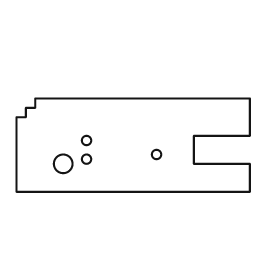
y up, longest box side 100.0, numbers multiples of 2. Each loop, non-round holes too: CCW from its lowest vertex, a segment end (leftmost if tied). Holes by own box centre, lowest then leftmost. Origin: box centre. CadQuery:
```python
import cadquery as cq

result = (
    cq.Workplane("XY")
    .moveTo(-50.0, -20.0)
    .lineTo(50.0, -20.0)
    .lineTo(50.0, -8.0)
    .lineTo(26.0, -8.0)
    .lineTo(26.0, 4.0)
    .lineTo(50.0, 4.0)
    .lineTo(50.0, 20.0)
    .lineTo(-42.0, 20.0)
    .lineTo(-42.0, 16.0)
    .lineTo(-46.0, 16.0)
    .lineTo(-46.0, 12.0)
    .lineTo(-50.0, 12.0)
    .close()
    .moveTo(-30.0, -8.0)
    .circle(4.0)
    .moveTo(-20.0, -6.0)
    .circle(2.0)
    .moveTo(10.0, -4.0)
    .circle(2.0)
    .moveTo(-20.0, 2.0)
    .circle(2.0)
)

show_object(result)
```